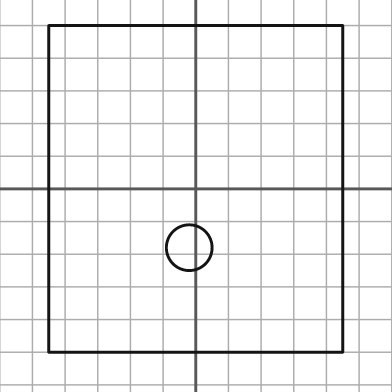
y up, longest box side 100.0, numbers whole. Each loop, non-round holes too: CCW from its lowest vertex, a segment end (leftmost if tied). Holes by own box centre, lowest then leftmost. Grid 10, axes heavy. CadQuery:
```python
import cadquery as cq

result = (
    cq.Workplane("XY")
    .moveTo(-45.0, -50.0)
    .lineTo(45.0, -50.0)
    .lineTo(45.0, 50.0)
    .lineTo(-45.0, 50.0)
    .close()
    .moveTo(-2.0, -18.0)
    .circle(7.0)
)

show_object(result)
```